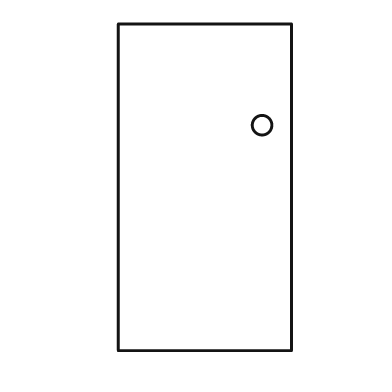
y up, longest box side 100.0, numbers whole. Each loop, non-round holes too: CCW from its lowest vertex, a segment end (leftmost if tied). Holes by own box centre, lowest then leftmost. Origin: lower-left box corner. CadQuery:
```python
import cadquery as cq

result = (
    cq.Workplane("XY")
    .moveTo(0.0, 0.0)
    .lineTo(53.0, 0.0)
    .lineTo(53.0, 100.0)
    .lineTo(0.0, 100.0)
    .close()
    .moveTo(44.0, 69.0)
    .circle(3.0)
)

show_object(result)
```